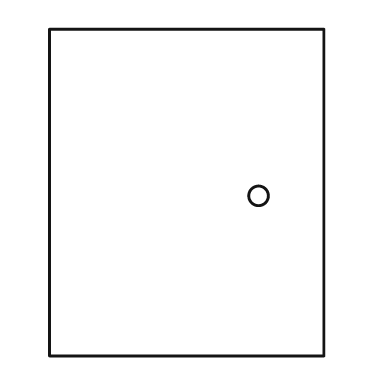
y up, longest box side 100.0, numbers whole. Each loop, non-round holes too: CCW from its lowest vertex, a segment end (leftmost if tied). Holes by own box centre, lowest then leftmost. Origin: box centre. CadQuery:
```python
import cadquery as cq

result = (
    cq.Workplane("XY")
    .moveTo(-42.0, -50.0)
    .lineTo(42.0, -50.0)
    .lineTo(42.0, 50.0)
    .lineTo(-42.0, 50.0)
    .close()
    .moveTo(22.0, -1.0)
    .circle(3.0)
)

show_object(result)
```